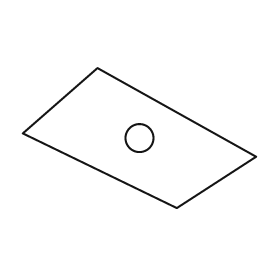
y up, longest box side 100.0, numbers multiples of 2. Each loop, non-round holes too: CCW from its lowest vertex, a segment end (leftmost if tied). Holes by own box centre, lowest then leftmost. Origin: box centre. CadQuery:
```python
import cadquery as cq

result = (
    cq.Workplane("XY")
    .moveTo(16.0, -30.0)
    .lineTo(50.0, -8.0)
    .lineTo(-18.0, 30.0)
    .lineTo(-50.0, 2.0)
    .close()
    .moveTo(0.0, 0.0)
    .circle(6.0)
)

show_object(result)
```